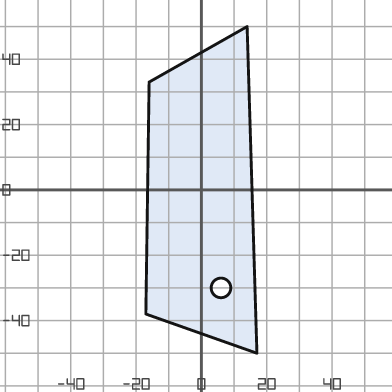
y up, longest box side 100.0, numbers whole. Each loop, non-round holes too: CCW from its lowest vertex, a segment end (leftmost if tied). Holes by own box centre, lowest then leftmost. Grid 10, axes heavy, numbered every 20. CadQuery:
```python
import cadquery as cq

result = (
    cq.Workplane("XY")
    .moveTo(17.0, -50.0)
    .lineTo(14.0, 50.0)
    .lineTo(-16.0, 33.0)
    .lineTo(-17.0, -38.0)
    .close()
    .moveTo(6.0, -30.0)
    .circle(3.0)
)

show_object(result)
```